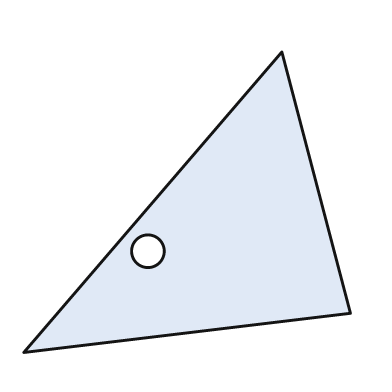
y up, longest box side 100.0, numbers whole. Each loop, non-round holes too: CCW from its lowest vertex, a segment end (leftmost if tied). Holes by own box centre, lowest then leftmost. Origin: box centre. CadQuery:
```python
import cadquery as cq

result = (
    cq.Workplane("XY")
    .moveTo(-50.0, -46.0)
    .lineTo(50.0, -34.0)
    .lineTo(29.0, 46.0)
    .close()
    .moveTo(-12.0, -15.0)
    .circle(5.0)
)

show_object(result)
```